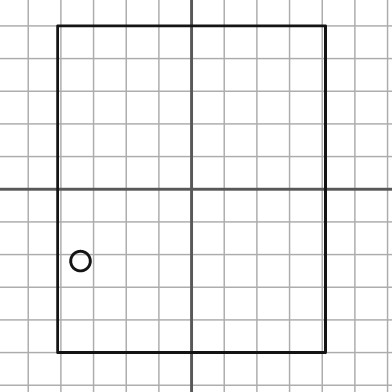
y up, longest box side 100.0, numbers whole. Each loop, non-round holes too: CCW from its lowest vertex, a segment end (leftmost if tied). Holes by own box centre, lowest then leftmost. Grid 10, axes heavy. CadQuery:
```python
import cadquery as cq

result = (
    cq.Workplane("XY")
    .moveTo(-41.0, -50.0)
    .lineTo(41.0, -50.0)
    .lineTo(41.0, 50.0)
    .lineTo(-41.0, 50.0)
    .close()
    .moveTo(-34.0, -22.0)
    .circle(3.0)
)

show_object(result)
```